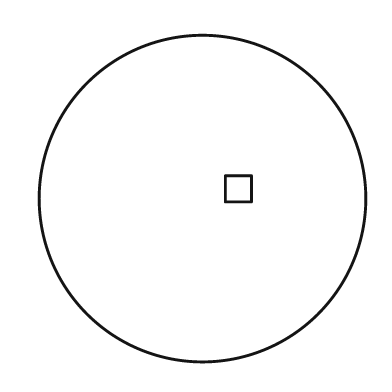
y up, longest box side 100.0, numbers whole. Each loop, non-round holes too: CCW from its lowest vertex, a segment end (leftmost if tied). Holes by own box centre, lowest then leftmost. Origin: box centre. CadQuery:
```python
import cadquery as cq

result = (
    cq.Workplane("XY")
    .moveTo(0.0, 0.0)
    .circle(50.0)
    .moveTo(7.0, -1.0)
    .lineTo(15.0, -1.0)
    .lineTo(15.0, 7.0)
    .lineTo(7.0, 7.0)
    .close()
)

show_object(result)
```